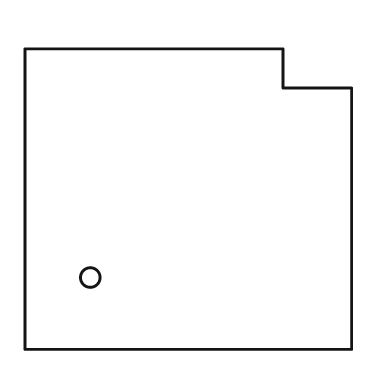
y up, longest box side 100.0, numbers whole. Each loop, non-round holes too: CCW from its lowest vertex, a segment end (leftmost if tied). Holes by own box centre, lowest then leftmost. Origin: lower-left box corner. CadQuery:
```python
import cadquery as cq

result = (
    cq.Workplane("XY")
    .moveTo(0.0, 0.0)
    .lineTo(100.0, 0.0)
    .lineTo(100.0, 80.0)
    .lineTo(79.0, 80.0)
    .lineTo(79.0, 92.0)
    .lineTo(0.0, 92.0)
    .close()
    .moveTo(20.0, 22.0)
    .circle(3.0)
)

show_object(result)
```